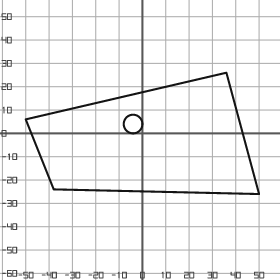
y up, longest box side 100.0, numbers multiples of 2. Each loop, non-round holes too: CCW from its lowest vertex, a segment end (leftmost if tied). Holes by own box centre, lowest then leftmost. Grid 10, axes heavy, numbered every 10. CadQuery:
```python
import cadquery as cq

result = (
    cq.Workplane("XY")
    .moveTo(50.0, -26.0)
    .lineTo(36.0, 26.0)
    .lineTo(-50.0, 6.0)
    .lineTo(-38.0, -24.0)
    .close()
    .moveTo(-4.0, 4.0)
    .circle(4.0)
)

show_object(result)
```